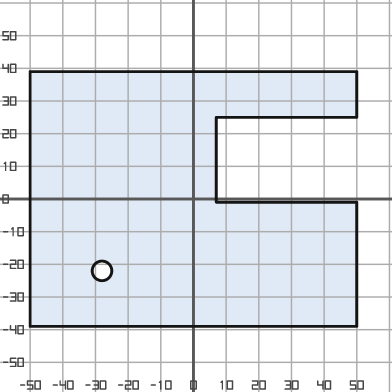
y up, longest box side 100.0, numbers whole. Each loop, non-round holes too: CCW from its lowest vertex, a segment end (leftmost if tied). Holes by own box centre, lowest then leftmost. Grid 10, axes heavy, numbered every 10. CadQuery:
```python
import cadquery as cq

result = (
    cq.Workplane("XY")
    .moveTo(-50.0, -39.0)
    .lineTo(50.0, -39.0)
    .lineTo(50.0, -1.0)
    .lineTo(7.0, -1.0)
    .lineTo(7.0, 25.0)
    .lineTo(50.0, 25.0)
    .lineTo(50.0, 39.0)
    .lineTo(-50.0, 39.0)
    .close()
    .moveTo(-28.0, -22.0)
    .circle(3.0)
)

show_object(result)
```